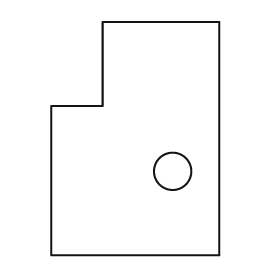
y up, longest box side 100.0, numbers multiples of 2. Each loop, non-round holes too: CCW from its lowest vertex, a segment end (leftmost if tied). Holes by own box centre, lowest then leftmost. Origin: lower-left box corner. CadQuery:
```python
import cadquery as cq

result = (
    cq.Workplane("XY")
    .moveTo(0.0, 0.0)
    .lineTo(72.0, 0.0)
    .lineTo(72.0, 100.0)
    .lineTo(22.0, 100.0)
    .lineTo(22.0, 64.0)
    .lineTo(0.0, 64.0)
    .close()
    .moveTo(52.0, 36.0)
    .circle(8.0)
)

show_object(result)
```